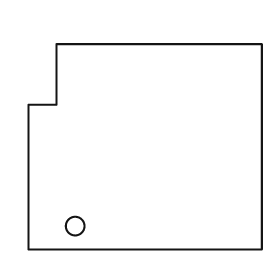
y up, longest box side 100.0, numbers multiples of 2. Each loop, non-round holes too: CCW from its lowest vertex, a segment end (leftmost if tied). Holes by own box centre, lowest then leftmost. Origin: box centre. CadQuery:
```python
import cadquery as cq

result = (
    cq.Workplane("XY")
    .moveTo(-50.0, -44.0)
    .lineTo(50.0, -44.0)
    .lineTo(50.0, 44.0)
    .lineTo(-38.0, 44.0)
    .lineTo(-38.0, 18.0)
    .lineTo(-50.0, 18.0)
    .close()
    .moveTo(-30.0, -34.0)
    .circle(4.0)
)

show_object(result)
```